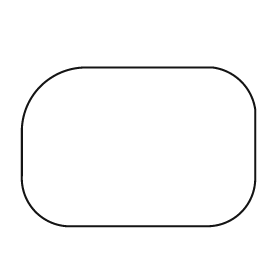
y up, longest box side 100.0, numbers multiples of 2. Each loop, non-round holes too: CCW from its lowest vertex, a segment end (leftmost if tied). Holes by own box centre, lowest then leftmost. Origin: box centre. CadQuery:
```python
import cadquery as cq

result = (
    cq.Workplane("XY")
    .moveTo(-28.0, -34.0)
    .lineTo(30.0, -34.0)
    .threePointArc((44.0, -28.0), (50.0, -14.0))
    .lineTo(50.0, 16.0)
    .threePointArc((44.0, 28.0), (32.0, 34.0))
    .lineTo(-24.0, 34.0)
    .threePointArc((-42.0, 26.0), (-50.0, 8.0))
    .lineTo(-50.0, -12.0)
    .threePointArc((-44.0, -28.0), (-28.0, -34.0))
    .close()
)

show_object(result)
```